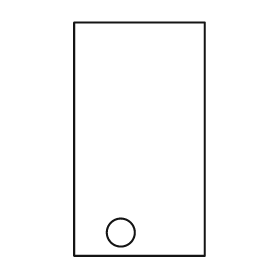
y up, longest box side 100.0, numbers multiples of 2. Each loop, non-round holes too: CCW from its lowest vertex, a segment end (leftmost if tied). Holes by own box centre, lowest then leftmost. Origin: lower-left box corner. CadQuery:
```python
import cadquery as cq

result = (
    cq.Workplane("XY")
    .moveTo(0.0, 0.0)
    .lineTo(56.0, 0.0)
    .lineTo(56.0, 100.0)
    .lineTo(0.0, 100.0)
    .close()
    .moveTo(20.0, 10.0)
    .circle(6.0)
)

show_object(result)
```